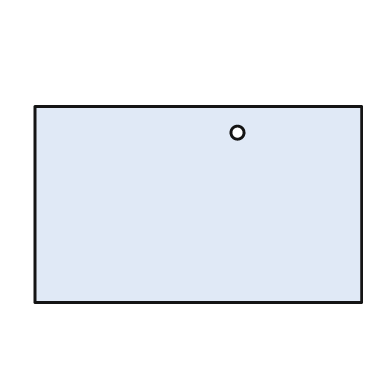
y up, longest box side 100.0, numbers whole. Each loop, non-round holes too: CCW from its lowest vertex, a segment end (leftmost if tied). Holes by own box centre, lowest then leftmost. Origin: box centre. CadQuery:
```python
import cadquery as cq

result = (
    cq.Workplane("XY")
    .moveTo(-50.0, -30.0)
    .lineTo(50.0, -30.0)
    .lineTo(50.0, 30.0)
    .lineTo(-50.0, 30.0)
    .close()
    .moveTo(12.0, 22.0)
    .circle(2.0)
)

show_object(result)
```